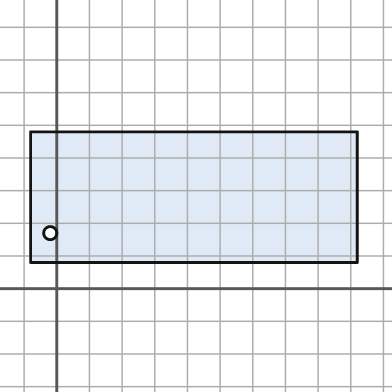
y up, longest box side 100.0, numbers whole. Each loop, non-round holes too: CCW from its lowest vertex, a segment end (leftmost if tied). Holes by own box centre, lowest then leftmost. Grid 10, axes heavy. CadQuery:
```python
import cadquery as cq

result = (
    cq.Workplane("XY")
    .moveTo(-8.0, 8.0)
    .lineTo(92.0, 8.0)
    .lineTo(92.0, 48.0)
    .lineTo(-8.0, 48.0)
    .close()
    .moveTo(-2.0, 17.0)
    .circle(2.0)
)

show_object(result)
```